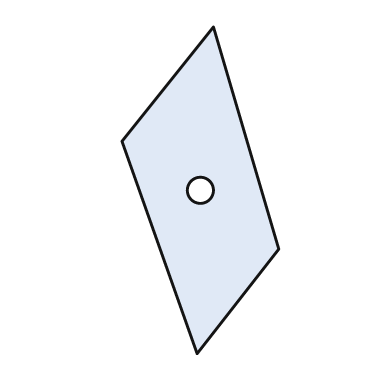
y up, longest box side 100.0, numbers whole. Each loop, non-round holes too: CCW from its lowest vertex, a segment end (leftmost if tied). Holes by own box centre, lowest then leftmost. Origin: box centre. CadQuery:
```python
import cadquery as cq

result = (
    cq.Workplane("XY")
    .moveTo(-1.0, -50.0)
    .lineTo(24.0, -18.0)
    .lineTo(4.0, 50.0)
    .lineTo(-24.0, 15.0)
    .close()
    .moveTo(0.0, 0.0)
    .circle(4.0)
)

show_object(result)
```